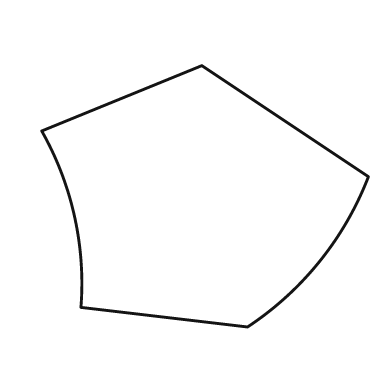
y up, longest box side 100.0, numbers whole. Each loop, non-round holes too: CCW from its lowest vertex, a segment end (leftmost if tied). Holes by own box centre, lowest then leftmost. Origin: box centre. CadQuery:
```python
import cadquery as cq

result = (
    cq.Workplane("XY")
    .moveTo(13.0, -40.0)
    .threePointArc((35.0, -20.0), (50.0, 6.0))
    .lineTo(-1.0, 40.0)
    .lineTo(-50.0, 20.0)
    .threePointArc((-40.0, -6.0), (-38.0, -34.0))
    .close()
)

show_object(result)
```